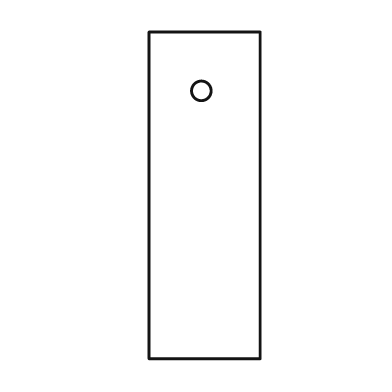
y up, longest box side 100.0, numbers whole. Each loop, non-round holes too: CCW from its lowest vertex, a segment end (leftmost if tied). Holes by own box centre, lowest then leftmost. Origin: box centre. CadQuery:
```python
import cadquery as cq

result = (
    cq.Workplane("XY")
    .moveTo(-17.0, -50.0)
    .lineTo(17.0, -50.0)
    .lineTo(17.0, 50.0)
    .lineTo(-17.0, 50.0)
    .close()
    .moveTo(-1.0, 32.0)
    .circle(3.0)
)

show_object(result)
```